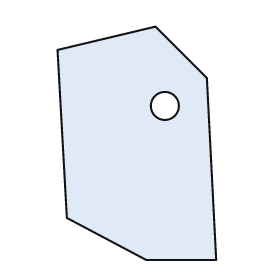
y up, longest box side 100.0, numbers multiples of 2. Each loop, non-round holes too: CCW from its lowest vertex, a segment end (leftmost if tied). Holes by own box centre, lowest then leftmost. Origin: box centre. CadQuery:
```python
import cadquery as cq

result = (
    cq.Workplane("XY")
    .moveTo(4.0, -50.0)
    .lineTo(34.0, -50.0)
    .lineTo(30.0, 28.0)
    .lineTo(8.0, 50.0)
    .lineTo(-34.0, 40.0)
    .lineTo(-30.0, -32.0)
    .close()
    .moveTo(12.0, 16.0)
    .circle(6.0)
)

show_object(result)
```